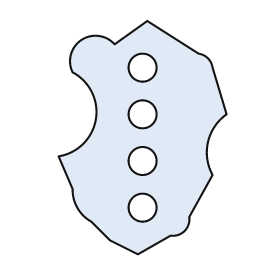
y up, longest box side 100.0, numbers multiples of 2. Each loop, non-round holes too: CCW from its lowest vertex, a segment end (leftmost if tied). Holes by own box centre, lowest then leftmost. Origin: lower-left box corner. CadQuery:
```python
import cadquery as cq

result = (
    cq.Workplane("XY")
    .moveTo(34.0, 0.0)
    .lineTo(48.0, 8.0)
    .threePointArc((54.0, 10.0), (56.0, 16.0))
    .lineTo(66.0, 34.0)
    .threePointArc((64.0, 48.0), (72.0, 60.0))
    .lineTo(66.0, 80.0)
    .threePointArc((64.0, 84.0), (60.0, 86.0))
    .lineTo(38.0, 100.0)
    .lineTo(24.0, 90.0)
    .threePointArc((10.0, 92.0), (6.0, 78.0))
    .threePointArc((16.0, 58.0), (0.0, 42.0))
    .lineTo(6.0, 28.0)
    .threePointArc((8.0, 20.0), (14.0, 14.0))
    .lineTo(22.0, 6.0)
    .close()
    .moveTo(36.0, 20.0)
    .circle(6.0)
    .moveTo(36.0, 40.0)
    .circle(6.0)
    .moveTo(36.0, 60.0)
    .circle(6.0)
    .moveTo(36.0, 80.0)
    .circle(6.0)
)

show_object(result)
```